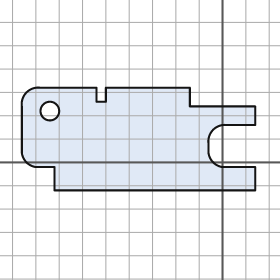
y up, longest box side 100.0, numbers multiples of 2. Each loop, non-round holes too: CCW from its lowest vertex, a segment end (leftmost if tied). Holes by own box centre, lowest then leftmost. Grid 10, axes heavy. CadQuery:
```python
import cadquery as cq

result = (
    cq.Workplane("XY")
    .moveTo(-72.0, -12.0)
    .lineTo(14.0, -12.0)
    .lineTo(14.0, -2.0)
    .lineTo(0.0, -2.0)
    .threePointArc((-4.0, 0.0), (-6.0, 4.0))
    .lineTo(-6.0, 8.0)
    .threePointArc((-4.0, 14.0), (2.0, 16.0))
    .lineTo(14.0, 16.0)
    .lineTo(14.0, 24.0)
    .lineTo(-14.0, 24.0)
    .lineTo(-14.0, 32.0)
    .lineTo(-50.0, 32.0)
    .lineTo(-50.0, 26.0)
    .lineTo(-54.0, 26.0)
    .lineTo(-54.0, 32.0)
    .lineTo(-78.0, 32.0)
    .threePointArc((-84.0, 30.0), (-86.0, 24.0))
    .lineTo(-86.0, 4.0)
    .threePointArc((-84.0, 0.0), (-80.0, -2.0))
    .lineTo(-72.0, -2.0)
    .close()
    .moveTo(-74.0, 22.0)
    .circle(4.0)
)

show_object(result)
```